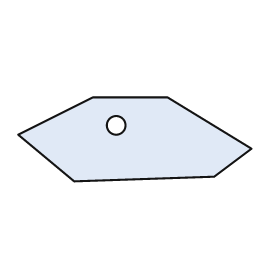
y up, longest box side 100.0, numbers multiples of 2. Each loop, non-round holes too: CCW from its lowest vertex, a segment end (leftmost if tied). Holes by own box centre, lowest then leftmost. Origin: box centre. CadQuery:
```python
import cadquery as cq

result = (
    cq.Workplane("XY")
    .moveTo(-26.0, -18.0)
    .lineTo(34.0, -16.0)
    .lineTo(50.0, -4.0)
    .lineTo(14.0, 18.0)
    .lineTo(-18.0, 18.0)
    .lineTo(-50.0, 2.0)
    .close()
    .moveTo(-8.0, 6.0)
    .circle(4.0)
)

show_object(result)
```